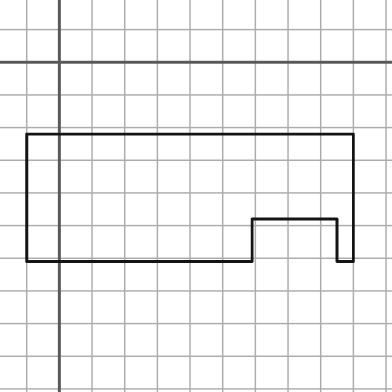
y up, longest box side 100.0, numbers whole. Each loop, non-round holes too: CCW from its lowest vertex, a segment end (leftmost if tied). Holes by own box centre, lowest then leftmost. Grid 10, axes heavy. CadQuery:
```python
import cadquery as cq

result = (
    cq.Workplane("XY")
    .moveTo(-10.0, -61.0)
    .lineTo(59.0, -61.0)
    .lineTo(59.0, -48.0)
    .lineTo(85.0, -48.0)
    .lineTo(85.0, -61.0)
    .lineTo(90.0, -61.0)
    .lineTo(90.0, -22.0)
    .lineTo(-10.0, -22.0)
    .close()
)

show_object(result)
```